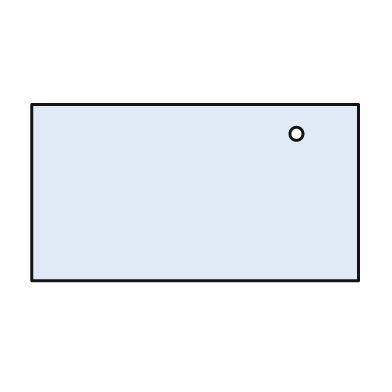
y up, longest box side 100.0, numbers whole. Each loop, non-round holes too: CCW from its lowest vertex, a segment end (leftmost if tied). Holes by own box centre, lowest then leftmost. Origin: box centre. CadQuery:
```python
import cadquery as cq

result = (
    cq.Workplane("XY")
    .moveTo(-50.0, -27.0)
    .lineTo(50.0, -27.0)
    .lineTo(50.0, 27.0)
    .lineTo(-50.0, 27.0)
    .close()
    .moveTo(31.0, 18.0)
    .circle(2.0)
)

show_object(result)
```